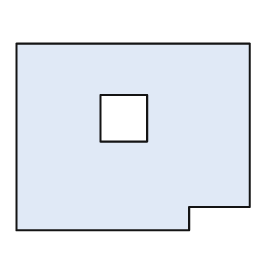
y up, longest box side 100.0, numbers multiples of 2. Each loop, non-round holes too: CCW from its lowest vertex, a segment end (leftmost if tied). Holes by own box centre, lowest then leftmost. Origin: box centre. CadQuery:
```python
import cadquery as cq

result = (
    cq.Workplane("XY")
    .moveTo(-50.0, -40.0)
    .lineTo(24.0, -40.0)
    .lineTo(24.0, -30.0)
    .lineTo(50.0, -30.0)
    .lineTo(50.0, 40.0)
    .lineTo(-50.0, 40.0)
    .close()
    .moveTo(-14.0, -2.0)
    .lineTo(6.0, -2.0)
    .lineTo(6.0, 18.0)
    .lineTo(-14.0, 18.0)
    .close()
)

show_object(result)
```